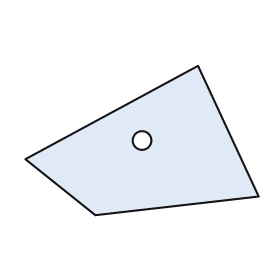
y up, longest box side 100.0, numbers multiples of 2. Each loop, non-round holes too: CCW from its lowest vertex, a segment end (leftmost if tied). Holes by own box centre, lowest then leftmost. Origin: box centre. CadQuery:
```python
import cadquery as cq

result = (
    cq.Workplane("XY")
    .moveTo(-20.0, -32.0)
    .lineTo(50.0, -24.0)
    .lineTo(24.0, 32.0)
    .lineTo(-50.0, -8.0)
    .close()
    .moveTo(0.0, 0.0)
    .circle(4.0)
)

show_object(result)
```